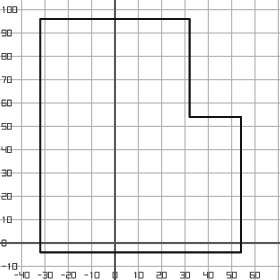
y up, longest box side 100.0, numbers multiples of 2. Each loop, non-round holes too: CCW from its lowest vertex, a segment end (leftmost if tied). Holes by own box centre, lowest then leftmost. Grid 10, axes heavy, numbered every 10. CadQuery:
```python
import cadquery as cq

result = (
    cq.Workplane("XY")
    .moveTo(-32.0, -4.0)
    .lineTo(54.0, -4.0)
    .lineTo(54.0, 54.0)
    .lineTo(32.0, 54.0)
    .lineTo(32.0, 96.0)
    .lineTo(-32.0, 96.0)
    .close()
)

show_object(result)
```